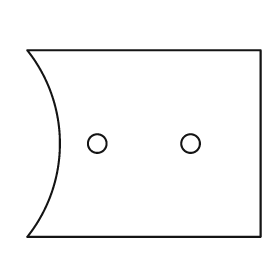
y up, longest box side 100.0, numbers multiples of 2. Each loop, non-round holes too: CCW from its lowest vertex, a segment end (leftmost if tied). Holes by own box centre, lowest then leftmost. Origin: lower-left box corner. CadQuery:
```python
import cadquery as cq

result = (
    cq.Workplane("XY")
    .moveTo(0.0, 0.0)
    .lineTo(100.0, 0.0)
    .lineTo(100.0, 80.0)
    .lineTo(0.0, 80.0)
    .threePointArc((14.0, 40.0), (0.0, 0.0))
    .close()
    .moveTo(30.0, 40.0)
    .circle(4.0)
    .moveTo(70.0, 40.0)
    .circle(4.0)
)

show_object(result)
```